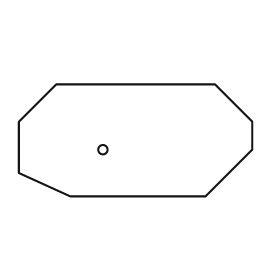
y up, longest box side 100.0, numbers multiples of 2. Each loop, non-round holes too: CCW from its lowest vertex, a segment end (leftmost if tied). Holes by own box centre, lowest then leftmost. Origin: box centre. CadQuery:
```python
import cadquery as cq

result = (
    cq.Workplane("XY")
    .moveTo(-28.0, -24.0)
    .lineTo(30.0, -24.0)
    .lineTo(50.0, -4.0)
    .lineTo(50.0, 8.0)
    .lineTo(34.0, 24.0)
    .lineTo(-34.0, 24.0)
    .lineTo(-50.0, 8.0)
    .lineTo(-50.0, -14.0)
    .close()
    .moveTo(-14.0, -4.0)
    .circle(2.0)
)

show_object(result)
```